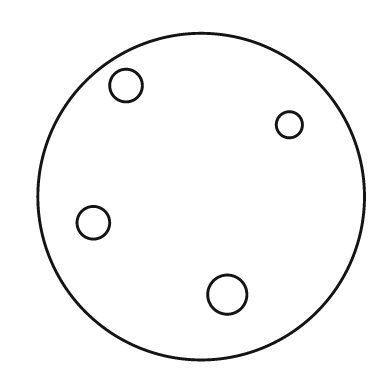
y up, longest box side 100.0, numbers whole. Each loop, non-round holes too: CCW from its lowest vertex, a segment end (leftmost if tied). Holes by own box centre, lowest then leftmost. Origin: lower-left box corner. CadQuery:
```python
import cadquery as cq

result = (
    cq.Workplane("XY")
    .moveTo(50.0, 50.0)
    .circle(50.0)
    .moveTo(58.0, 20.0)
    .circle(6.0)
    .moveTo(17.0, 42.0)
    .circle(5.0)
    .moveTo(77.0, 72.0)
    .circle(4.0)
    .moveTo(27.0, 84.0)
    .circle(5.0)
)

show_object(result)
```